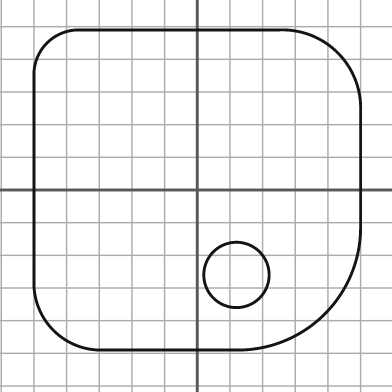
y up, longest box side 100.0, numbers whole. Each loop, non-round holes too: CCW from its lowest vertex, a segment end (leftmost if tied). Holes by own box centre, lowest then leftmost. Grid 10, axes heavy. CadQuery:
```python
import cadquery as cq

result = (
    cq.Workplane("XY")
    .moveTo(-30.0, -49.0)
    .lineTo(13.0, -49.0)
    .threePointArc((39.0, -38.0), (50.0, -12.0))
    .lineTo(50.0, 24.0)
    .threePointArc((43.0, 42.0), (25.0, 49.0))
    .lineTo(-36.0, 49.0)
    .threePointArc((-46.0, 45.0), (-50.0, 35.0))
    .lineTo(-50.0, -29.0)
    .threePointArc((-44.0, -43.0), (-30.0, -49.0))
    .close()
    .moveTo(12.0, -26.0)
    .circle(10.0)
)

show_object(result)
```